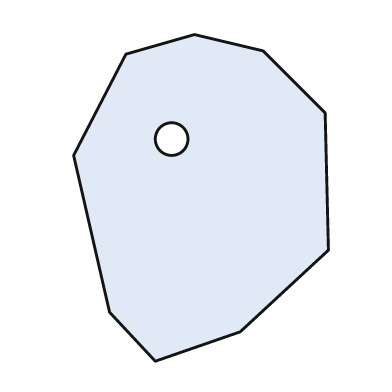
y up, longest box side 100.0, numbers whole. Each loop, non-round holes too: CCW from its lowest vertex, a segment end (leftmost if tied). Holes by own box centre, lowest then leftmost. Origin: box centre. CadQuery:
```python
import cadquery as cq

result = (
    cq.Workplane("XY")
    .moveTo(-14.0, -50.0)
    .lineTo(12.0, -41.0)
    .lineTo(39.0, -16.0)
    .lineTo(38.0, 26.0)
    .lineTo(19.0, 45.0)
    .lineTo(-2.0, 50.0)
    .lineTo(-23.0, 44.0)
    .lineTo(-39.0, 13.0)
    .lineTo(-28.0, -35.0)
    .close()
    .moveTo(-9.0, 18.0)
    .circle(5.0)
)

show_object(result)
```